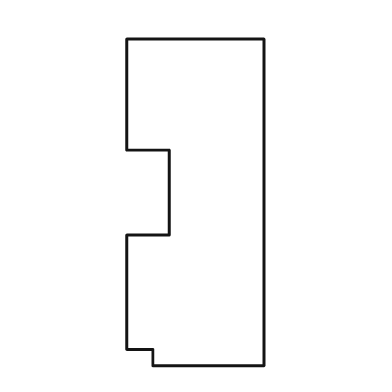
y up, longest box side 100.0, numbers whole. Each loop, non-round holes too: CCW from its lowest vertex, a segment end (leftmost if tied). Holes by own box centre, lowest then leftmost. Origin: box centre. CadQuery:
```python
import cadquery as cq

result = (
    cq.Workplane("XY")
    .moveTo(-13.0, -50.0)
    .lineTo(21.0, -50.0)
    .lineTo(21.0, 50.0)
    .lineTo(-21.0, 50.0)
    .lineTo(-21.0, 16.0)
    .lineTo(-8.0, 16.0)
    .lineTo(-8.0, -10.0)
    .lineTo(-21.0, -10.0)
    .lineTo(-21.0, -45.0)
    .lineTo(-13.0, -45.0)
    .close()
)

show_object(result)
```